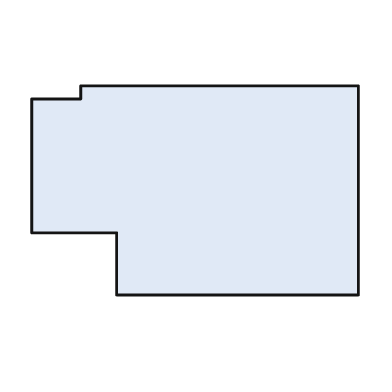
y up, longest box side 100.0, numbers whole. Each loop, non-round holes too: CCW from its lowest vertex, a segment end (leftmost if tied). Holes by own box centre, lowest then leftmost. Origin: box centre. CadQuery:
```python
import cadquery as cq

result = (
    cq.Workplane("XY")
    .moveTo(-24.0, -32.0)
    .lineTo(50.0, -32.0)
    .lineTo(50.0, 32.0)
    .lineTo(-35.0, 32.0)
    .lineTo(-35.0, 28.0)
    .lineTo(-50.0, 28.0)
    .lineTo(-50.0, -13.0)
    .lineTo(-24.0, -13.0)
    .close()
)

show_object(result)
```